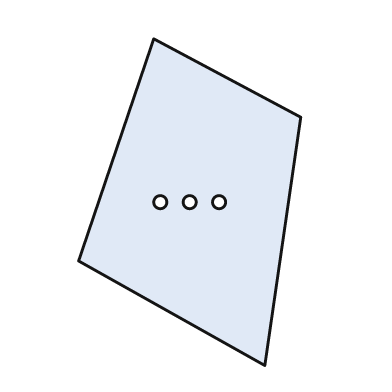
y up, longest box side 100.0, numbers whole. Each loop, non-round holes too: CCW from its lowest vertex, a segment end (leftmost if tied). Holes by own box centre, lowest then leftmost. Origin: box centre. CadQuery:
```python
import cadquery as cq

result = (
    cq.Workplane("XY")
    .moveTo(23.0, -50.0)
    .lineTo(34.0, 26.0)
    .lineTo(-11.0, 50.0)
    .lineTo(-34.0, -18.0)
    .close()
    .moveTo(-9.0, 0.0)
    .circle(2.0)
    .moveTo(0.0, 0.0)
    .circle(2.0)
    .moveTo(9.0, 0.0)
    .circle(2.0)
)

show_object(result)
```